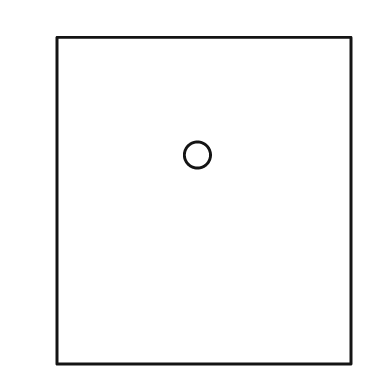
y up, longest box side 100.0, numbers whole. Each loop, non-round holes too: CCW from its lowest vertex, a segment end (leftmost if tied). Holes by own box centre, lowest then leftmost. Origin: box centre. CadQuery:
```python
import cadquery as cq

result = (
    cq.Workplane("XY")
    .moveTo(-45.0, -50.0)
    .lineTo(45.0, -50.0)
    .lineTo(45.0, 50.0)
    .lineTo(-45.0, 50.0)
    .close()
    .moveTo(-2.0, 14.0)
    .circle(4.0)
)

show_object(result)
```